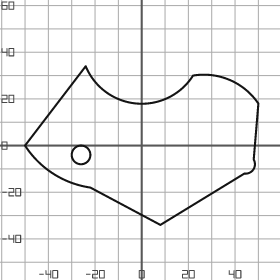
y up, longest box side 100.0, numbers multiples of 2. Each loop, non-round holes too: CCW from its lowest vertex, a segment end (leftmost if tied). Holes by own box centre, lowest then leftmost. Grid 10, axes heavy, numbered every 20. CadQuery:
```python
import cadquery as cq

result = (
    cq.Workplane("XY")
    .moveTo(8.0, -34.0)
    .lineTo(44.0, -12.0)
    .threePointArc((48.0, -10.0), (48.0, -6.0))
    .lineTo(50.0, 18.0)
    .threePointArc((38.0, 28.0), (22.0, 30.0))
    .threePointArc((-2.0, 18.0), (-24.0, 34.0))
    .lineTo(-50.0, 0.0)
    .threePointArc((-38.0, -12.0), (-22.0, -18.0))
    .close()
    .moveTo(-26.0, -4.0)
    .circle(4.0)
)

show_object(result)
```